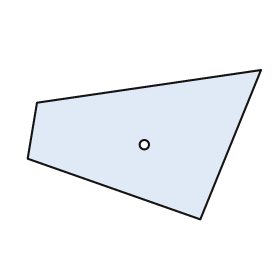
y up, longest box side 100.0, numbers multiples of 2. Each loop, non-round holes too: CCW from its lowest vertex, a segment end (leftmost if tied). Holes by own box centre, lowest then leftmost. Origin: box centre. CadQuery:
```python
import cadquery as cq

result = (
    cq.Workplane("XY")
    .moveTo(24.0, -32.0)
    .lineTo(50.0, 32.0)
    .lineTo(-46.0, 18.0)
    .lineTo(-50.0, -6.0)
    .close()
    .moveTo(0.0, 0.0)
    .circle(2.0)
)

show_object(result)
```